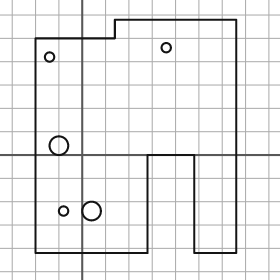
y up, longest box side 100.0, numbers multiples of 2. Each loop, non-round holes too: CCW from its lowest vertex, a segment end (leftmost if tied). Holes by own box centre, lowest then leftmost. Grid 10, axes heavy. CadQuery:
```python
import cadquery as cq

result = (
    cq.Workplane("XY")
    .moveTo(-20.0, -42.0)
    .lineTo(28.0, -42.0)
    .lineTo(28.0, 0.0)
    .lineTo(48.0, 0.0)
    .lineTo(48.0, -42.0)
    .lineTo(66.0, -42.0)
    .lineTo(66.0, 58.0)
    .lineTo(14.0, 58.0)
    .lineTo(14.0, 50.0)
    .lineTo(-20.0, 50.0)
    .close()
    .moveTo(-8.0, -24.0)
    .circle(2.0)
    .moveTo(4.0, -24.0)
    .circle(4.0)
    .moveTo(-10.0, 4.0)
    .circle(4.0)
    .moveTo(-14.0, 42.0)
    .circle(2.0)
    .moveTo(36.0, 46.0)
    .circle(2.0)
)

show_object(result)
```